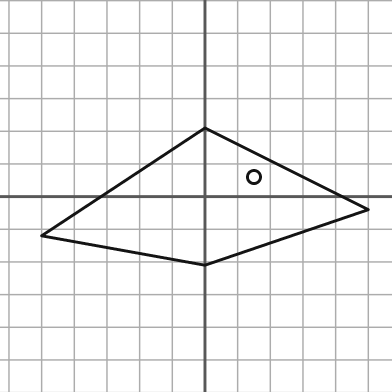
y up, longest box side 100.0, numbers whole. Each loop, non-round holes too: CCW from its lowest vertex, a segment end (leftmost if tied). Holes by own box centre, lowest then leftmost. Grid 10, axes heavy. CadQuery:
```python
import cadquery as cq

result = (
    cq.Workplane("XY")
    .moveTo(0.0, -21.0)
    .lineTo(50.0, -4.0)
    .lineTo(0.0, 21.0)
    .lineTo(-50.0, -12.0)
    .close()
    .moveTo(15.0, 6.0)
    .circle(2.0)
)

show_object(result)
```